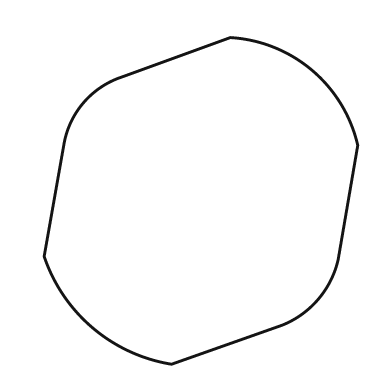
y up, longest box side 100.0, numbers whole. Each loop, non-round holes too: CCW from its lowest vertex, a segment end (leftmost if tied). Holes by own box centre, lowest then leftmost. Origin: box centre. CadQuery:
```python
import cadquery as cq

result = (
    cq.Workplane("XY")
    .moveTo(-9.0, -50.0)
    .lineTo(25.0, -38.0)
    .threePointArc((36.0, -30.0), (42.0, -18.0))
    .lineTo(48.0, 17.0)
    .threePointArc((34.0, 40.0), (9.0, 50.0))
    .lineTo(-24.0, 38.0)
    .threePointArc((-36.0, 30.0), (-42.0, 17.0))
    .lineTo(-48.0, -17.0)
    .threePointArc((-33.0, -39.0), (-9.0, -50.0))
    .close()
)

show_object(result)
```